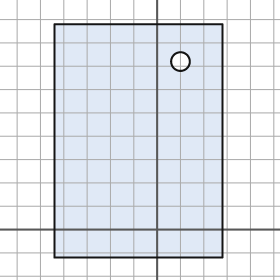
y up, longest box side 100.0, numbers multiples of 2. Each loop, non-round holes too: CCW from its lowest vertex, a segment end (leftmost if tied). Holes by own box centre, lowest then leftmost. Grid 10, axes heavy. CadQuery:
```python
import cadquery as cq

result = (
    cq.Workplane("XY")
    .moveTo(-44.0, -12.0)
    .lineTo(28.0, -12.0)
    .lineTo(28.0, 88.0)
    .lineTo(-44.0, 88.0)
    .close()
    .moveTo(10.0, 72.0)
    .circle(4.0)
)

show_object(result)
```